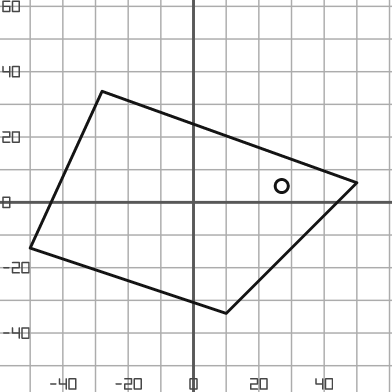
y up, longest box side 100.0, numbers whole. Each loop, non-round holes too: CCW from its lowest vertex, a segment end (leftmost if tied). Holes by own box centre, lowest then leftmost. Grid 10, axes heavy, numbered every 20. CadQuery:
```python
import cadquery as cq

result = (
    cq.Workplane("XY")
    .moveTo(10.0, -34.0)
    .lineTo(50.0, 6.0)
    .lineTo(-28.0, 34.0)
    .lineTo(-50.0, -14.0)
    .close()
    .moveTo(27.0, 5.0)
    .circle(2.0)
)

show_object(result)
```